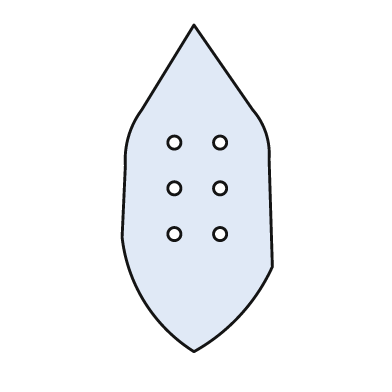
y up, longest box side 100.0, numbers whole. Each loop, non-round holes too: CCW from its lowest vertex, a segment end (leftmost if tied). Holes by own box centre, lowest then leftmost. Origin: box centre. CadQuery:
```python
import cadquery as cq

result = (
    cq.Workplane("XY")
    .moveTo(-1.0, -50.0)
    .threePointArc((13.0, -39.0), (23.0, -24.0))
    .lineTo(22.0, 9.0)
    .threePointArc((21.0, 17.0), (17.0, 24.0))
    .lineTo(-1.0, 50.0)
    .lineTo(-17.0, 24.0)
    .threePointArc((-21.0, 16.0), (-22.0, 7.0))
    .lineTo(-23.0, -15.0)
    .threePointArc((-16.0, -35.0), (-1.0, -50.0))
    .close()
    .moveTo(-7.0, -14.0)
    .circle(2.0)
    .moveTo(7.0, -14.0)
    .circle(2.0)
    .moveTo(-7.0, 0.0)
    .circle(2.0)
    .moveTo(7.0, 0.0)
    .circle(2.0)
    .moveTo(-7.0, 14.0)
    .circle(2.0)
    .moveTo(7.0, 14.0)
    .circle(2.0)
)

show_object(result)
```